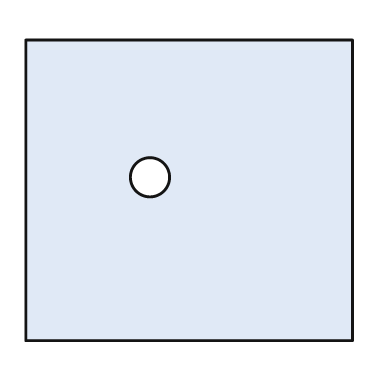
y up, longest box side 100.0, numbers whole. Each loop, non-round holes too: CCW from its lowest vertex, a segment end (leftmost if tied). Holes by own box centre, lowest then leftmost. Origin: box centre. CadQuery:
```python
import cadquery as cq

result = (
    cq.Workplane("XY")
    .moveTo(-50.0, -46.0)
    .lineTo(50.0, -46.0)
    .lineTo(50.0, 46.0)
    .lineTo(-50.0, 46.0)
    .close()
    .moveTo(-12.0, 4.0)
    .circle(6.0)
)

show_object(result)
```